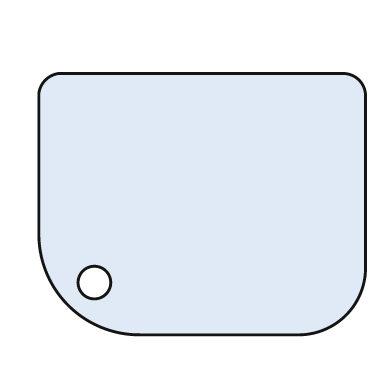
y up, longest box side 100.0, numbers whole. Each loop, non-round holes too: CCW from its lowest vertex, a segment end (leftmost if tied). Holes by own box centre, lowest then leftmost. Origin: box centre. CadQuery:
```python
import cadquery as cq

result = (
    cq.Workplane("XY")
    .moveTo(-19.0, -40.0)
    .lineTo(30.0, -40.0)
    .threePointArc((44.0, -34.0), (50.0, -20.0))
    .lineTo(50.0, 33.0)
    .threePointArc((48.0, 38.0), (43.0, 40.0))
    .lineTo(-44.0, 40.0)
    .threePointArc((-48.0, 38.0), (-50.0, 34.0))
    .lineTo(-50.0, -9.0)
    .threePointArc((-41.0, -31.0), (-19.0, -40.0))
    .close()
    .moveTo(-33.0, -24.0)
    .circle(5.0)
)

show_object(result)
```